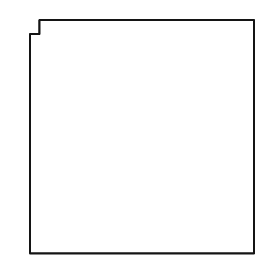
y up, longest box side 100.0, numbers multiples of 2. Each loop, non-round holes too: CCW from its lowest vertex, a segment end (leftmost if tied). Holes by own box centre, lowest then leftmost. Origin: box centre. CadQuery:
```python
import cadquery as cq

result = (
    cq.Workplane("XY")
    .moveTo(-48.0, -50.0)
    .lineTo(48.0, -50.0)
    .lineTo(48.0, 50.0)
    .lineTo(-44.0, 50.0)
    .lineTo(-44.0, 44.0)
    .lineTo(-48.0, 44.0)
    .close()
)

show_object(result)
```